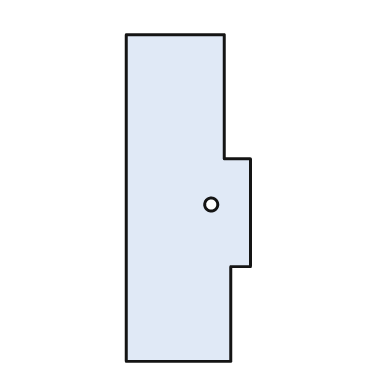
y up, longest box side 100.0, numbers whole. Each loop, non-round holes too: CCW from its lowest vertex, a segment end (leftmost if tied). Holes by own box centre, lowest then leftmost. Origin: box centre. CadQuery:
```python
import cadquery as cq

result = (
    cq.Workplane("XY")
    .moveTo(-19.0, -50.0)
    .lineTo(13.0, -50.0)
    .lineTo(13.0, -21.0)
    .lineTo(19.0, -21.0)
    .lineTo(19.0, 12.0)
    .lineTo(11.0, 12.0)
    .lineTo(11.0, 50.0)
    .lineTo(-19.0, 50.0)
    .close()
    .moveTo(7.0, -2.0)
    .circle(2.0)
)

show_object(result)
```